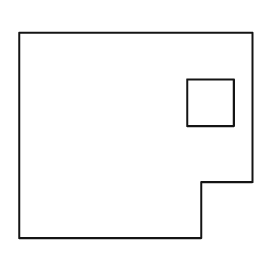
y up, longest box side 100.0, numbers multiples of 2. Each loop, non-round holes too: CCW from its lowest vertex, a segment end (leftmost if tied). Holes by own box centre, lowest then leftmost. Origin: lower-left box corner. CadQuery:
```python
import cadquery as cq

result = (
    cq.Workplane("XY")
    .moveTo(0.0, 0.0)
    .lineTo(78.0, 0.0)
    .lineTo(78.0, 24.0)
    .lineTo(100.0, 24.0)
    .lineTo(100.0, 88.0)
    .lineTo(0.0, 88.0)
    .close()
    .moveTo(72.0, 48.0)
    .lineTo(92.0, 48.0)
    .lineTo(92.0, 68.0)
    .lineTo(72.0, 68.0)
    .close()
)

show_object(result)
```